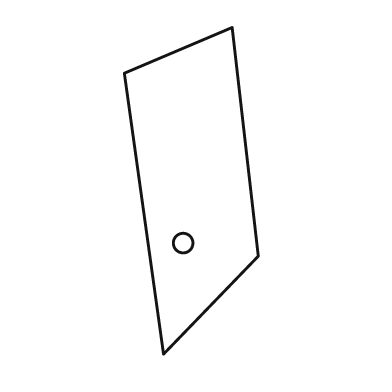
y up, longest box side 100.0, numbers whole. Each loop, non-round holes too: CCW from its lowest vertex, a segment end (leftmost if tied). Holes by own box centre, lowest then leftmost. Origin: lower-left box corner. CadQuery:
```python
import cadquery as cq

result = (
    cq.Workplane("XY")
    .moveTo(12.0, 0.0)
    .lineTo(41.0, 30.0)
    .lineTo(33.0, 100.0)
    .lineTo(0.0, 86.0)
    .close()
    .moveTo(18.0, 34.0)
    .circle(3.0)
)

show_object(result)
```